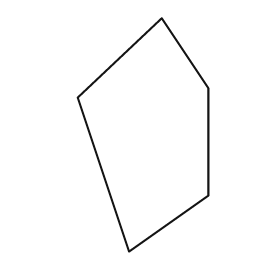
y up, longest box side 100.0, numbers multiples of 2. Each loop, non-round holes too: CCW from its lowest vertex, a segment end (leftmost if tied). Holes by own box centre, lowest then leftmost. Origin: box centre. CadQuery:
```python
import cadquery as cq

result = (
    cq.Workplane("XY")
    .moveTo(-6.0, -50.0)
    .lineTo(28.0, -26.0)
    .lineTo(28.0, 20.0)
    .lineTo(8.0, 50.0)
    .lineTo(-28.0, 16.0)
    .close()
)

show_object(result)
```